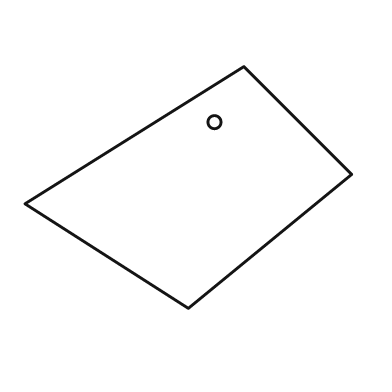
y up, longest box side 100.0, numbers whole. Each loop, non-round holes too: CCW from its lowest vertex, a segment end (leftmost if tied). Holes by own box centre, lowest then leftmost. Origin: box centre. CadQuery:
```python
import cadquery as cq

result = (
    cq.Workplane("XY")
    .moveTo(0.0, -37.0)
    .lineTo(50.0, 4.0)
    .lineTo(17.0, 37.0)
    .lineTo(-50.0, -5.0)
    .close()
    .moveTo(8.0, 20.0)
    .circle(2.0)
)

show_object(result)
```